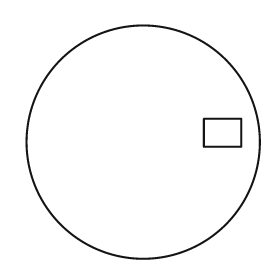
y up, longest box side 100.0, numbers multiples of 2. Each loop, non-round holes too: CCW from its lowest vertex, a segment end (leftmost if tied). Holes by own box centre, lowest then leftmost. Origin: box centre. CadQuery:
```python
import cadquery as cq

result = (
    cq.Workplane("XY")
    .moveTo(0.0, 0.0)
    .circle(50.0)
    .moveTo(26.0, -2.0)
    .lineTo(42.0, -2.0)
    .lineTo(42.0, 10.0)
    .lineTo(26.0, 10.0)
    .close()
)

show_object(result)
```